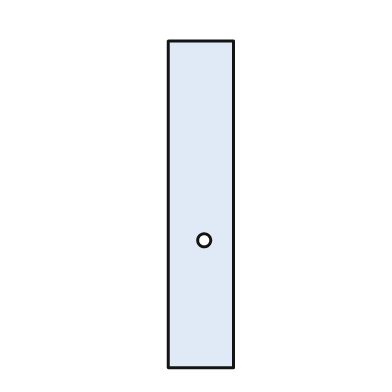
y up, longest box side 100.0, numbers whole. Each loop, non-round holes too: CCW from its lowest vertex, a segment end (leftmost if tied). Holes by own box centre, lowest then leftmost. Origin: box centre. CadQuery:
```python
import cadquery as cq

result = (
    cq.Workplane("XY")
    .moveTo(-10.0, -50.0)
    .lineTo(10.0, -50.0)
    .lineTo(10.0, 50.0)
    .lineTo(-10.0, 50.0)
    .close()
    .moveTo(1.0, -11.0)
    .circle(2.0)
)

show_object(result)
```